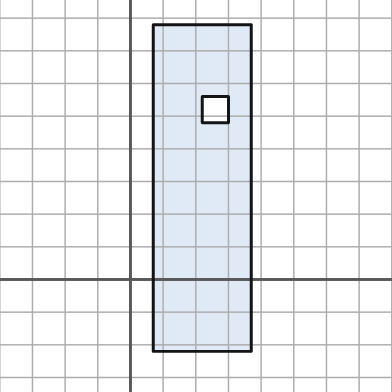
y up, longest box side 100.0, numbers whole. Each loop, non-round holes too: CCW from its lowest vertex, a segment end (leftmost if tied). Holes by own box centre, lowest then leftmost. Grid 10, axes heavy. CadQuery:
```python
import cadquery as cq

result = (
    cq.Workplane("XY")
    .moveTo(7.0, -22.0)
    .lineTo(37.0, -22.0)
    .lineTo(37.0, 78.0)
    .lineTo(7.0, 78.0)
    .close()
    .moveTo(22.0, 48.0)
    .lineTo(30.0, 48.0)
    .lineTo(30.0, 56.0)
    .lineTo(22.0, 56.0)
    .close()
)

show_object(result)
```